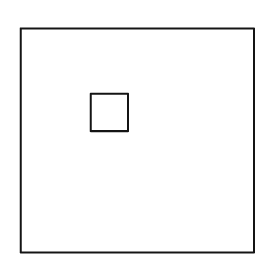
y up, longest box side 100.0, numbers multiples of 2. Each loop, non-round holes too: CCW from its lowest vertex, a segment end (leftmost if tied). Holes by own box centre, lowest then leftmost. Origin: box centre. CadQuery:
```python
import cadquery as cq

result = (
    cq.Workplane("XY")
    .moveTo(-50.0, -48.0)
    .lineTo(50.0, -48.0)
    .lineTo(50.0, 48.0)
    .lineTo(-50.0, 48.0)
    .close()
    .moveTo(-20.0, 4.0)
    .lineTo(-4.0, 4.0)
    .lineTo(-4.0, 20.0)
    .lineTo(-20.0, 20.0)
    .close()
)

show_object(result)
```